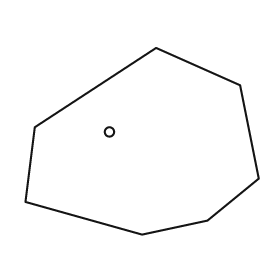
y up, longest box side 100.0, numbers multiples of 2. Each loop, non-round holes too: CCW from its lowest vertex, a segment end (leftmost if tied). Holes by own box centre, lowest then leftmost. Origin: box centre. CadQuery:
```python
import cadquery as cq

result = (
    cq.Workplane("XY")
    .moveTo(0.0, -40.0)
    .lineTo(28.0, -34.0)
    .lineTo(50.0, -16.0)
    .lineTo(42.0, 24.0)
    .lineTo(6.0, 40.0)
    .lineTo(-46.0, 6.0)
    .lineTo(-50.0, -26.0)
    .close()
    .moveTo(-14.0, 4.0)
    .circle(2.0)
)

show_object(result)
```